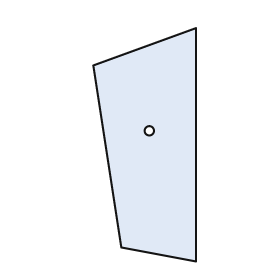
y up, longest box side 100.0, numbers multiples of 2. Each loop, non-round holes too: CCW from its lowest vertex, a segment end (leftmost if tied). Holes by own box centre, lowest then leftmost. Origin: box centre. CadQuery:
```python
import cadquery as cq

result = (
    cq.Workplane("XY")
    .moveTo(22.0, -50.0)
    .lineTo(22.0, 50.0)
    .lineTo(-22.0, 34.0)
    .lineTo(-10.0, -44.0)
    .close()
    .moveTo(2.0, 6.0)
    .circle(2.0)
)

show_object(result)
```